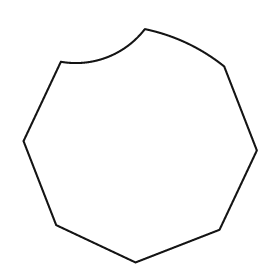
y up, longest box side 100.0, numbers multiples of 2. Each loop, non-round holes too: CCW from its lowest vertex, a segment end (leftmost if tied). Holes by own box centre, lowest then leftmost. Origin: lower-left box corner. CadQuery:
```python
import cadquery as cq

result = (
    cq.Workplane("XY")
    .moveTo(48.0, 0.0)
    .lineTo(84.0, 14.0)
    .lineTo(100.0, 48.0)
    .lineTo(86.0, 84.0)
    .threePointArc((70.0, 94.0), (52.0, 100.0))
    .threePointArc((36.0, 88.0), (16.0, 86.0))
    .lineTo(0.0, 52.0)
    .lineTo(14.0, 16.0)
    .close()
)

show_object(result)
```